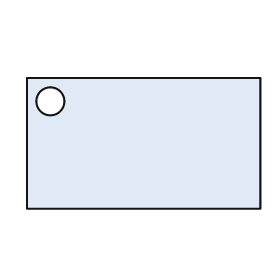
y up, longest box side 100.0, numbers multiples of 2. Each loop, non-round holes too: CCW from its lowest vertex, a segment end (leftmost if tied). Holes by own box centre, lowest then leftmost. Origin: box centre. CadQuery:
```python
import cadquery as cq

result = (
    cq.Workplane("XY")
    .moveTo(-50.0, -28.0)
    .lineTo(50.0, -28.0)
    .lineTo(50.0, 28.0)
    .lineTo(-50.0, 28.0)
    .close()
    .moveTo(-40.0, 18.0)
    .circle(6.0)
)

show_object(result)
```